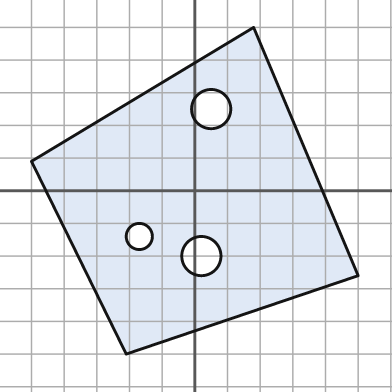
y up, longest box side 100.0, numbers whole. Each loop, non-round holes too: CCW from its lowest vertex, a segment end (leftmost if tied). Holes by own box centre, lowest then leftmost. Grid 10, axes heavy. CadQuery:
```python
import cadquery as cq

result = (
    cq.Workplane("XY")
    .moveTo(-21.0, -50.0)
    .lineTo(50.0, -26.0)
    .lineTo(18.0, 50.0)
    .lineTo(-50.0, 9.0)
    .close()
    .moveTo(2.0, -20.0)
    .circle(6.0)
    .moveTo(-17.0, -14.0)
    .circle(4.0)
    .moveTo(5.0, 25.0)
    .circle(6.0)
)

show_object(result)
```